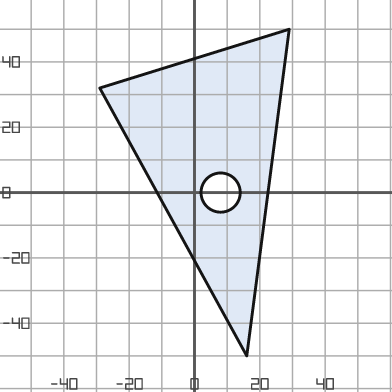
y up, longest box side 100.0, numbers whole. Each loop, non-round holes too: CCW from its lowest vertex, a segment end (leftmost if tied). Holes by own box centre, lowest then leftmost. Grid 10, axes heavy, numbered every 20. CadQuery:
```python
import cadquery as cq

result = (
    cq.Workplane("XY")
    .moveTo(16.0, -50.0)
    .lineTo(29.0, 50.0)
    .lineTo(-29.0, 32.0)
    .close()
    .moveTo(8.0, 0.0)
    .circle(6.0)
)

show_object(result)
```